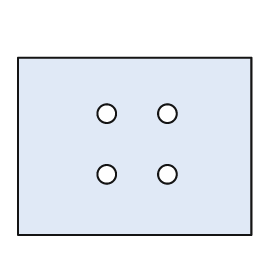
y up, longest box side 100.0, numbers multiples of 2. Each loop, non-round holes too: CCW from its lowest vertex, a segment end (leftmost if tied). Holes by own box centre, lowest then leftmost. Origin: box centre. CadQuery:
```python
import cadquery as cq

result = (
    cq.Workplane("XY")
    .moveTo(-50.0, -38.0)
    .lineTo(50.0, -38.0)
    .lineTo(50.0, 38.0)
    .lineTo(-50.0, 38.0)
    .close()
    .moveTo(-12.0, -12.0)
    .circle(4.0)
    .moveTo(14.0, -12.0)
    .circle(4.0)
    .moveTo(-12.0, 14.0)
    .circle(4.0)
    .moveTo(14.0, 14.0)
    .circle(4.0)
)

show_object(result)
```